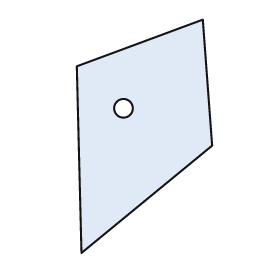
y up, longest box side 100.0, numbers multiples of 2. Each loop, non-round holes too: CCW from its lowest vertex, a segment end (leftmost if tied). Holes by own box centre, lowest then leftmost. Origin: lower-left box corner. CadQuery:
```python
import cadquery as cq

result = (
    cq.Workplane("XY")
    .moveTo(2.0, 0.0)
    .lineTo(58.0, 46.0)
    .lineTo(54.0, 100.0)
    .lineTo(0.0, 80.0)
    .close()
    .moveTo(20.0, 62.0)
    .circle(4.0)
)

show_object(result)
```